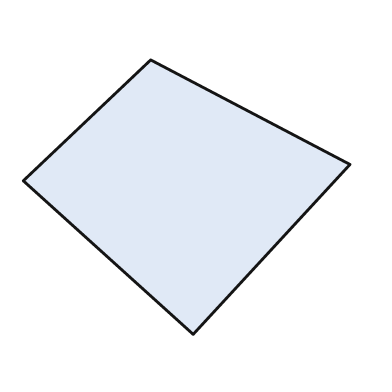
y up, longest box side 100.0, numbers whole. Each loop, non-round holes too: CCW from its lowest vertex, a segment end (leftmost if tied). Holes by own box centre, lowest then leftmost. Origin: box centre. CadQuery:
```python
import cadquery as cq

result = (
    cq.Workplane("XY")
    .moveTo(2.0, -42.0)
    .lineTo(50.0, 10.0)
    .lineTo(-11.0, 42.0)
    .lineTo(-50.0, 5.0)
    .close()
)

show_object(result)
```